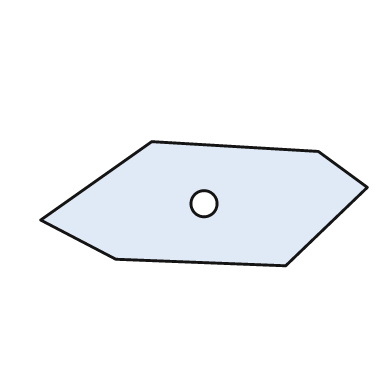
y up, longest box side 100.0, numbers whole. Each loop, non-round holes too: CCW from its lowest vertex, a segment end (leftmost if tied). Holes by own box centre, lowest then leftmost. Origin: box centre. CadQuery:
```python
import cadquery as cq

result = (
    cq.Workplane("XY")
    .moveTo(25.0, -19.0)
    .lineTo(50.0, 5.0)
    .lineTo(35.0, 16.0)
    .lineTo(-16.0, 19.0)
    .lineTo(-50.0, -5.0)
    .lineTo(-27.0, -17.0)
    .close()
    .moveTo(0.0, 0.0)
    .circle(4.0)
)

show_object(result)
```